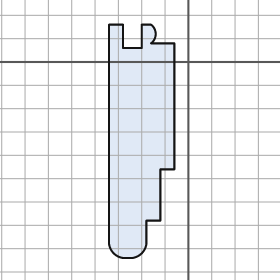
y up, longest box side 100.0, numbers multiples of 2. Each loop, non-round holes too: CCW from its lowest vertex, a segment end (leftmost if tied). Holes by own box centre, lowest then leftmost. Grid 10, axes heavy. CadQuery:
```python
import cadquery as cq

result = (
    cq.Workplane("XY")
    .moveTo(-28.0, -84.0)
    .lineTo(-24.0, -84.0)
    .threePointArc((-20.0, -82.0), (-18.0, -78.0))
    .lineTo(-18.0, -68.0)
    .lineTo(-12.0, -68.0)
    .lineTo(-12.0, -46.0)
    .lineTo(-6.0, -46.0)
    .lineTo(-6.0, 8.0)
    .lineTo(-16.0, 8.0)
    .threePointArc((-14.0, 12.0), (-16.0, 16.0))
    .lineTo(-20.0, 16.0)
    .lineTo(-20.0, 6.0)
    .lineTo(-28.0, 6.0)
    .lineTo(-28.0, 16.0)
    .lineTo(-34.0, 16.0)
    .lineTo(-34.0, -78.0)
    .threePointArc((-32.0, -82.0), (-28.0, -84.0))
    .close()
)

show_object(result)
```